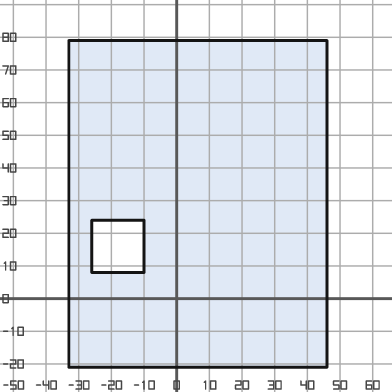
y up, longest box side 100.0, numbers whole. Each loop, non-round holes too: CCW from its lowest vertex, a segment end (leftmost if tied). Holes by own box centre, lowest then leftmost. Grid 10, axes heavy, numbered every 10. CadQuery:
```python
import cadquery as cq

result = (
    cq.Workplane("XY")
    .moveTo(-33.0, -21.0)
    .lineTo(46.0, -21.0)
    .lineTo(46.0, 79.0)
    .lineTo(-33.0, 79.0)
    .close()
    .moveTo(-26.0, 8.0)
    .lineTo(-10.0, 8.0)
    .lineTo(-10.0, 24.0)
    .lineTo(-26.0, 24.0)
    .close()
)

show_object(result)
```